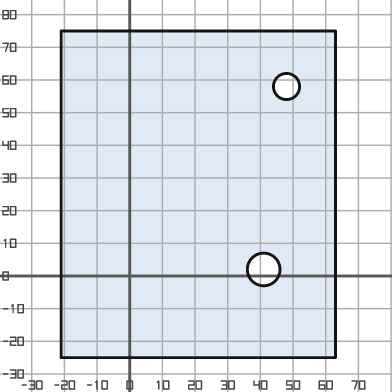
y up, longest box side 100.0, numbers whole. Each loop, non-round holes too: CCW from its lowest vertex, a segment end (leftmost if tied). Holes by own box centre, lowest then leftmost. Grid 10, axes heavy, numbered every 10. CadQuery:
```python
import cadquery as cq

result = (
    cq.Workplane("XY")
    .moveTo(-21.0, -25.0)
    .lineTo(63.0, -25.0)
    .lineTo(63.0, 75.0)
    .lineTo(-21.0, 75.0)
    .close()
    .moveTo(41.0, 2.0)
    .circle(5.0)
    .moveTo(48.0, 58.0)
    .circle(4.0)
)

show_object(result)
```